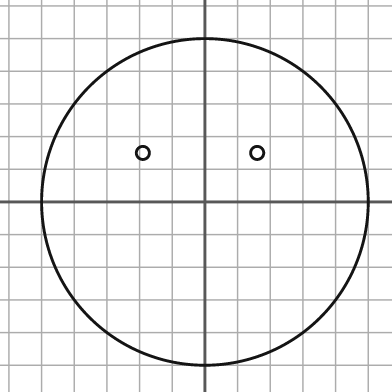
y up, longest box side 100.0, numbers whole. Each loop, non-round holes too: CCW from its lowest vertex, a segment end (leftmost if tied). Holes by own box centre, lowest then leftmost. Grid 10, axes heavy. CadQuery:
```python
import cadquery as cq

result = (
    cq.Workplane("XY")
    .moveTo(0.0, 0.0)
    .circle(50.0)
    .moveTo(-19.0, 15.0)
    .circle(2.0)
    .moveTo(16.0, 15.0)
    .circle(2.0)
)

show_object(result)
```